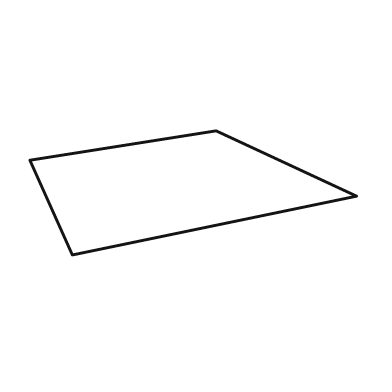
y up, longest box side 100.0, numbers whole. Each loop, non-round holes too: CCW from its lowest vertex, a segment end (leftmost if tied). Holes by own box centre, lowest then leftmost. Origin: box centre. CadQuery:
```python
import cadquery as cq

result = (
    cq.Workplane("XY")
    .moveTo(-37.0, -19.0)
    .lineTo(50.0, -1.0)
    .lineTo(7.0, 19.0)
    .lineTo(-50.0, 10.0)
    .close()
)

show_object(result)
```